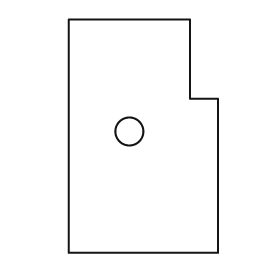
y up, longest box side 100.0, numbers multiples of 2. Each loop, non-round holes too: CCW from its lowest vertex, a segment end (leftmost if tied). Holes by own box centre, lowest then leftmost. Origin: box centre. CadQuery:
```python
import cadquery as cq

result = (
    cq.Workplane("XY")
    .moveTo(-32.0, -50.0)
    .lineTo(32.0, -50.0)
    .lineTo(32.0, 16.0)
    .lineTo(20.0, 16.0)
    .lineTo(20.0, 50.0)
    .lineTo(-32.0, 50.0)
    .close()
    .moveTo(-6.0, 2.0)
    .circle(6.0)
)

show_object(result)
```